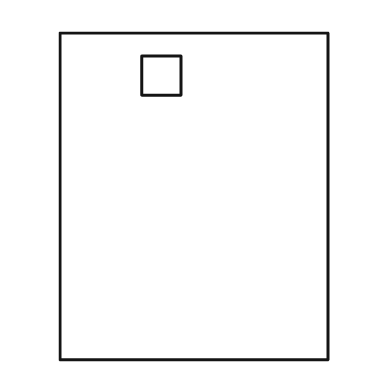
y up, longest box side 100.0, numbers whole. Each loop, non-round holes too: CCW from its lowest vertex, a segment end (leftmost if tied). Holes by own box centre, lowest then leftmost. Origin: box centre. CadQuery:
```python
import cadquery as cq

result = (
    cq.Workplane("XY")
    .moveTo(-41.0, -50.0)
    .lineTo(41.0, -50.0)
    .lineTo(41.0, 50.0)
    .lineTo(-41.0, 50.0)
    .close()
    .moveTo(-16.0, 31.0)
    .lineTo(-4.0, 31.0)
    .lineTo(-4.0, 43.0)
    .lineTo(-16.0, 43.0)
    .close()
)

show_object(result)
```